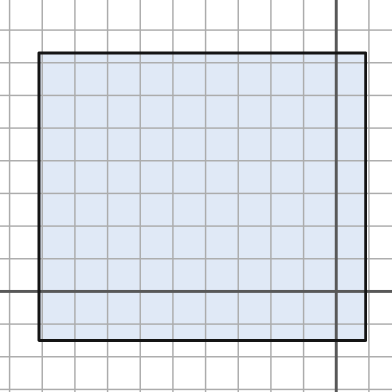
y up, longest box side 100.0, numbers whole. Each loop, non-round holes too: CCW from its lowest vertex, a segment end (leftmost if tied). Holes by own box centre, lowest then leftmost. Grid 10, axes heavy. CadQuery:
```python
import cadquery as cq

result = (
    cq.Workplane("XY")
    .moveTo(-91.0, -15.0)
    .lineTo(9.0, -15.0)
    .lineTo(9.0, 73.0)
    .lineTo(-91.0, 73.0)
    .close()
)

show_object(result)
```